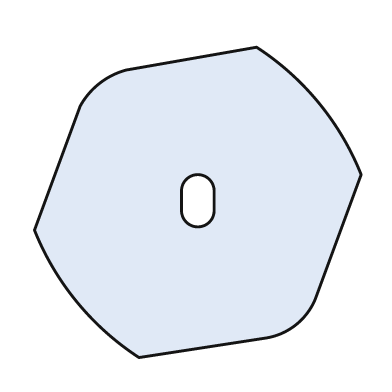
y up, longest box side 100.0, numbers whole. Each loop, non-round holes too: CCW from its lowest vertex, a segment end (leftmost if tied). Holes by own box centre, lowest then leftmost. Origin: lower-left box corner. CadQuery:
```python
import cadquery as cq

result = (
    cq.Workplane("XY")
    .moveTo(32.0, 0.0)
    .lineTo(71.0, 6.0)
    .threePointArc((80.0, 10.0), (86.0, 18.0))
    .lineTo(100.0, 56.0)
    .threePointArc((87.0, 78.0), (68.0, 95.0))
    .lineTo(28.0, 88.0)
    .threePointArc((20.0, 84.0), (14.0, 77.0))
    .lineTo(0.0, 39.0)
    .threePointArc((13.0, 17.0), (32.0, 0.0))
    .close()
    .moveTo(45.0, 45.0)
    .threePointArc((50.0, 40.0), (55.0, 45.0))
    .lineTo(55.0, 51.0)
    .threePointArc((50.0, 56.0), (45.0, 51.0))
    .close()
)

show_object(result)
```